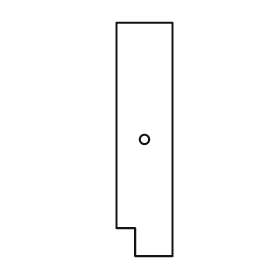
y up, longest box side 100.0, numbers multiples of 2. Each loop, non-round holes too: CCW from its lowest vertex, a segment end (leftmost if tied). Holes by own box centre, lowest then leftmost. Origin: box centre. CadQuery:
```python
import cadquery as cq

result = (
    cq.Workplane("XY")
    .moveTo(-4.0, -50.0)
    .lineTo(12.0, -50.0)
    .lineTo(12.0, 50.0)
    .lineTo(-12.0, 50.0)
    .lineTo(-12.0, -38.0)
    .lineTo(-4.0, -38.0)
    .close()
    .moveTo(0.0, 0.0)
    .circle(2.0)
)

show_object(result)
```